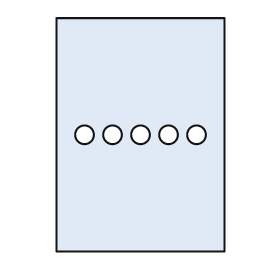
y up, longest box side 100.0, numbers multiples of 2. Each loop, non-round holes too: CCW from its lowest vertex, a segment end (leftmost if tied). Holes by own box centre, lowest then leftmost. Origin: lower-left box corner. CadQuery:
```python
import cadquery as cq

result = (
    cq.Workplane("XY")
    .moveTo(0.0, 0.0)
    .lineTo(72.0, 0.0)
    .lineTo(72.0, 100.0)
    .lineTo(0.0, 100.0)
    .close()
    .moveTo(12.0, 50.0)
    .circle(4.0)
    .moveTo(24.0, 50.0)
    .circle(4.0)
    .moveTo(36.0, 50.0)
    .circle(4.0)
    .moveTo(48.0, 50.0)
    .circle(4.0)
    .moveTo(60.0, 50.0)
    .circle(4.0)
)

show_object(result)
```